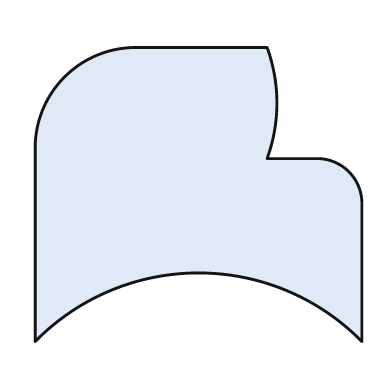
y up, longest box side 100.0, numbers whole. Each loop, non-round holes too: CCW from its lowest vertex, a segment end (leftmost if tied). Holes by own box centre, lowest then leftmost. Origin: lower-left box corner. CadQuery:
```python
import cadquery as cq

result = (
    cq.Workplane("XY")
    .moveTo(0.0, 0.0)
    .threePointArc((50.0, 21.0), (100.0, 0.0))
    .lineTo(100.0, 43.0)
    .threePointArc((96.0, 52.0), (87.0, 56.0))
    .lineTo(71.0, 56.0)
    .threePointArc((74.0, 73.0), (71.0, 90.0))
    .lineTo(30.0, 90.0)
    .threePointArc((9.0, 81.0), (0.0, 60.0))
    .close()
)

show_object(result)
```